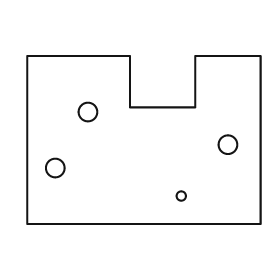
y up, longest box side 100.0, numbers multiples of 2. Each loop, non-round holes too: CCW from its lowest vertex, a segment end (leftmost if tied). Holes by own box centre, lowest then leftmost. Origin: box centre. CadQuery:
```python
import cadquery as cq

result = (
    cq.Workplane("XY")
    .moveTo(-50.0, -36.0)
    .lineTo(50.0, -36.0)
    .lineTo(50.0, 36.0)
    .lineTo(22.0, 36.0)
    .lineTo(22.0, 14.0)
    .lineTo(-6.0, 14.0)
    .lineTo(-6.0, 36.0)
    .lineTo(-50.0, 36.0)
    .close()
    .moveTo(16.0, -24.0)
    .circle(2.0)
    .moveTo(-38.0, -12.0)
    .circle(4.0)
    .moveTo(36.0, -2.0)
    .circle(4.0)
    .moveTo(-24.0, 12.0)
    .circle(4.0)
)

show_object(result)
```